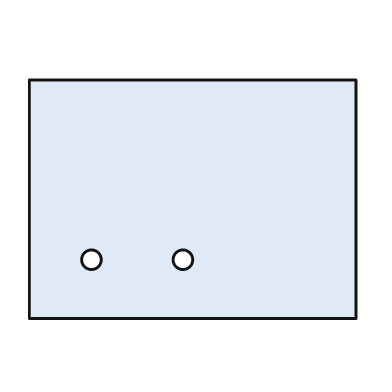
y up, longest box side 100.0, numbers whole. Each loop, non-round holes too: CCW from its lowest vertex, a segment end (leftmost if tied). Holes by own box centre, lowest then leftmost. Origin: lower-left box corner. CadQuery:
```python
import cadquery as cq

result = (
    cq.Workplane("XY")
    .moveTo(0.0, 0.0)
    .lineTo(100.0, 0.0)
    .lineTo(100.0, 73.0)
    .lineTo(0.0, 73.0)
    .close()
    .moveTo(19.0, 18.0)
    .circle(3.0)
    .moveTo(47.0, 18.0)
    .circle(3.0)
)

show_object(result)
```